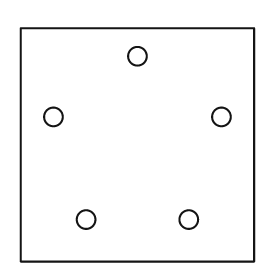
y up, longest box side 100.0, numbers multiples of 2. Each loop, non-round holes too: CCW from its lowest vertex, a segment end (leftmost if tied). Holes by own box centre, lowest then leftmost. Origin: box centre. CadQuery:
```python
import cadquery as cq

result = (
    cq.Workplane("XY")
    .moveTo(-50.0, -50.0)
    .lineTo(50.0, -50.0)
    .lineTo(50.0, 50.0)
    .lineTo(-50.0, 50.0)
    .close()
    .moveTo(-22.0, -32.0)
    .circle(4.0)
    .moveTo(22.0, -32.0)
    .circle(4.0)
    .moveTo(-36.0, 12.0)
    .circle(4.0)
    .moveTo(36.0, 12.0)
    .circle(4.0)
    .moveTo(0.0, 38.0)
    .circle(4.0)
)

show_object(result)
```